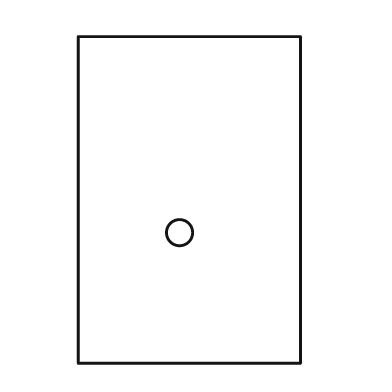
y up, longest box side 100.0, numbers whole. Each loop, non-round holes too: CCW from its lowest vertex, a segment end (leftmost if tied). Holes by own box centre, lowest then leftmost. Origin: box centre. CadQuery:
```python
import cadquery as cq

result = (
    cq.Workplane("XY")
    .moveTo(-34.0, -50.0)
    .lineTo(34.0, -50.0)
    .lineTo(34.0, 50.0)
    .lineTo(-34.0, 50.0)
    .close()
    .moveTo(-3.0, -10.0)
    .circle(4.0)
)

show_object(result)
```